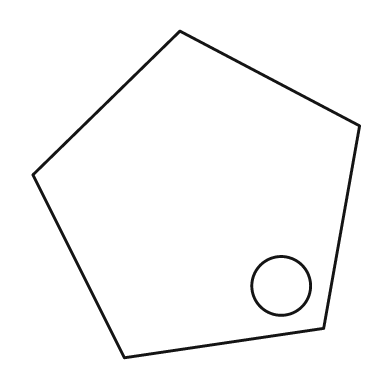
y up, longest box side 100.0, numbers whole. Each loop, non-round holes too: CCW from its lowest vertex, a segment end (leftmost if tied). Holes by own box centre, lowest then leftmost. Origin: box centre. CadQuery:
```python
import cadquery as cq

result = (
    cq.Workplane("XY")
    .moveTo(-22.0, -50.0)
    .lineTo(39.0, -41.0)
    .lineTo(50.0, 21.0)
    .lineTo(-5.0, 50.0)
    .lineTo(-50.0, 6.0)
    .close()
    .moveTo(26.0, -28.0)
    .circle(9.0)
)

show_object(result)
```